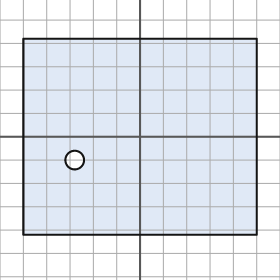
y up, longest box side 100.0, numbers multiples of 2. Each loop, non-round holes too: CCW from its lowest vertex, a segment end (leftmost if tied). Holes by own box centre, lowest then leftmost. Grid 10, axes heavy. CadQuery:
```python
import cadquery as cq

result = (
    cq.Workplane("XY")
    .moveTo(-50.0, -42.0)
    .lineTo(50.0, -42.0)
    .lineTo(50.0, 42.0)
    .lineTo(-50.0, 42.0)
    .close()
    .moveTo(-28.0, -10.0)
    .circle(4.0)
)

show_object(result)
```